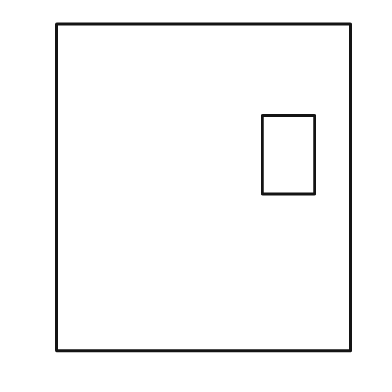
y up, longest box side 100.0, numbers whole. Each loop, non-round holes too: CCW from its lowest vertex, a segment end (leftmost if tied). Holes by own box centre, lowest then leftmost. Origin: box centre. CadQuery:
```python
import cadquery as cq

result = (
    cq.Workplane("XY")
    .moveTo(-45.0, -50.0)
    .lineTo(45.0, -50.0)
    .lineTo(45.0, 50.0)
    .lineTo(-45.0, 50.0)
    .close()
    .moveTo(18.0, -2.0)
    .lineTo(34.0, -2.0)
    .lineTo(34.0, 22.0)
    .lineTo(18.0, 22.0)
    .close()
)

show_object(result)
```